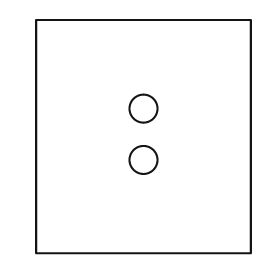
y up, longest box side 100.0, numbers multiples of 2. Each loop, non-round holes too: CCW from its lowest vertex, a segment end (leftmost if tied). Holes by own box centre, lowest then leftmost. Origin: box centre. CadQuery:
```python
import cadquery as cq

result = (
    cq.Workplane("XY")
    .moveTo(-46.0, -50.0)
    .lineTo(46.0, -50.0)
    .lineTo(46.0, 50.0)
    .lineTo(-46.0, 50.0)
    .close()
    .moveTo(0.0, -10.0)
    .circle(6.0)
    .moveTo(0.0, 12.0)
    .circle(6.0)
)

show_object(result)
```